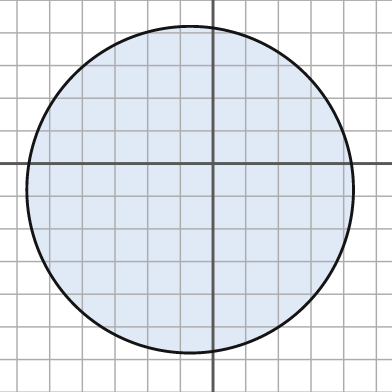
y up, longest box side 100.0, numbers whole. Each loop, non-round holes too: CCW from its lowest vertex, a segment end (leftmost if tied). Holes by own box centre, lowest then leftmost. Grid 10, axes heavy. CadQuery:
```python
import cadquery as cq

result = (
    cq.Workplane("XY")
    .moveTo(-7.0, -8.0)
    .circle(50.0)
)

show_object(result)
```